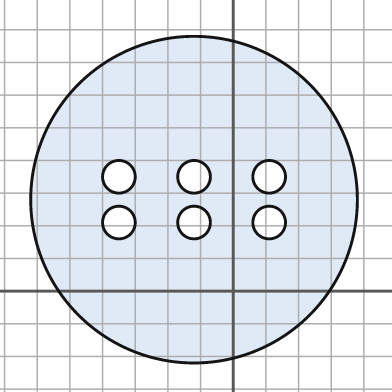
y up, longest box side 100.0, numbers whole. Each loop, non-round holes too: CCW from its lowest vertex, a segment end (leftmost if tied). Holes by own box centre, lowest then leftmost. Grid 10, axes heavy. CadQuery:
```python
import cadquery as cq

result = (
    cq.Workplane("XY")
    .moveTo(-12.0, 28.0)
    .circle(50.0)
    .moveTo(-35.0, 21.0)
    .circle(5.0)
    .moveTo(-12.0, 21.0)
    .circle(5.0)
    .moveTo(11.0, 21.0)
    .circle(5.0)
    .moveTo(-35.0, 35.0)
    .circle(5.0)
    .moveTo(-12.0, 35.0)
    .circle(5.0)
    .moveTo(11.0, 35.0)
    .circle(5.0)
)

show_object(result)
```